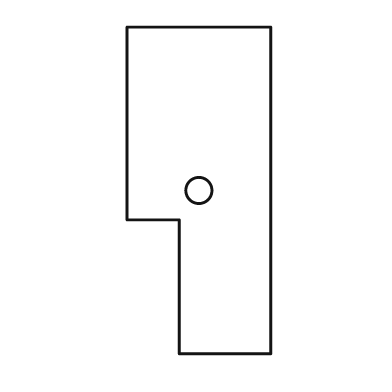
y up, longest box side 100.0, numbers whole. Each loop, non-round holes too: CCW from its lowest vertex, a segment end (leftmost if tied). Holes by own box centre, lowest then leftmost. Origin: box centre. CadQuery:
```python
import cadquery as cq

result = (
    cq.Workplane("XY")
    .moveTo(-6.0, -50.0)
    .lineTo(22.0, -50.0)
    .lineTo(22.0, 50.0)
    .lineTo(-22.0, 50.0)
    .lineTo(-22.0, -9.0)
    .lineTo(-6.0, -9.0)
    .close()
    .moveTo(0.0, 0.0)
    .circle(4.0)
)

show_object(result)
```